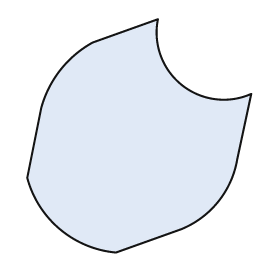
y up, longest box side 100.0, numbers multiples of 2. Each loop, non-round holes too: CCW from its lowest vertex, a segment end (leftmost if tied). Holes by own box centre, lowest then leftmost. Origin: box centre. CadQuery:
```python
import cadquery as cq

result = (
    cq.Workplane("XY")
    .moveTo(-10.0, -50.0)
    .lineTo(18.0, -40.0)
    .threePointArc((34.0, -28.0), (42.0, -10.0))
    .lineTo(48.0, 18.0)
    .threePointArc((18.0, 22.0), (8.0, 50.0))
    .lineTo(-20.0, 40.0)
    .threePointArc((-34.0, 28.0), (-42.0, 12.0))
    .lineTo(-48.0, -18.0)
    .threePointArc((-34.0, -40.0), (-10.0, -50.0))
    .close()
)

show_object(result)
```